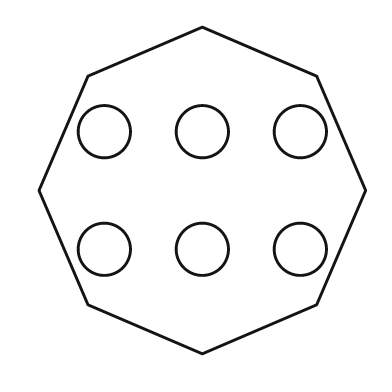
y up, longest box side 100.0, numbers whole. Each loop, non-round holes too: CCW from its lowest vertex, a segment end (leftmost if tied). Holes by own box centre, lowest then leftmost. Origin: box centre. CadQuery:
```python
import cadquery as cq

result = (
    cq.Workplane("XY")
    .moveTo(0.0, -50.0)
    .lineTo(35.0, -35.0)
    .lineTo(50.0, 0.0)
    .lineTo(35.0, 35.0)
    .lineTo(0.0, 50.0)
    .lineTo(-35.0, 35.0)
    .lineTo(-50.0, 0.0)
    .lineTo(-35.0, -35.0)
    .close()
    .moveTo(-30.0, -18.0)
    .circle(8.0)
    .moveTo(0.0, -18.0)
    .circle(8.0)
    .moveTo(30.0, -18.0)
    .circle(8.0)
    .moveTo(-30.0, 18.0)
    .circle(8.0)
    .moveTo(0.0, 18.0)
    .circle(8.0)
    .moveTo(30.0, 18.0)
    .circle(8.0)
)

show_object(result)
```